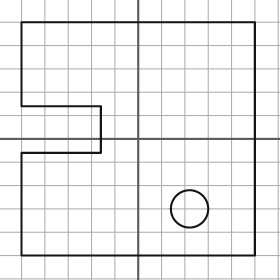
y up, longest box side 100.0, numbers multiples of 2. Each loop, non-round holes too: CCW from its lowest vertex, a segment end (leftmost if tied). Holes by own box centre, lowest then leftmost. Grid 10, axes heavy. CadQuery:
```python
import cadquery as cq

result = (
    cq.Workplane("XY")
    .moveTo(-50.0, -50.0)
    .lineTo(50.0, -50.0)
    .lineTo(50.0, 50.0)
    .lineTo(-50.0, 50.0)
    .lineTo(-50.0, 14.0)
    .lineTo(-16.0, 14.0)
    .lineTo(-16.0, -6.0)
    .lineTo(-50.0, -6.0)
    .close()
    .moveTo(22.0, -30.0)
    .circle(8.0)
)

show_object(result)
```